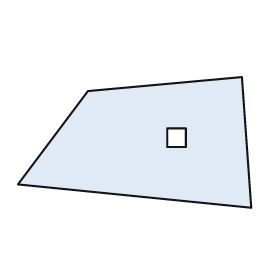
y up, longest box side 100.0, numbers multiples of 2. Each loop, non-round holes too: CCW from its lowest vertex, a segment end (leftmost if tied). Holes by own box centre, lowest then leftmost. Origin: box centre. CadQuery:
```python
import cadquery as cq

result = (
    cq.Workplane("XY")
    .moveTo(50.0, -28.0)
    .lineTo(46.0, 28.0)
    .lineTo(-20.0, 22.0)
    .lineTo(-50.0, -18.0)
    .close()
    .moveTo(14.0, -2.0)
    .lineTo(22.0, -2.0)
    .lineTo(22.0, 6.0)
    .lineTo(14.0, 6.0)
    .close()
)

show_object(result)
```